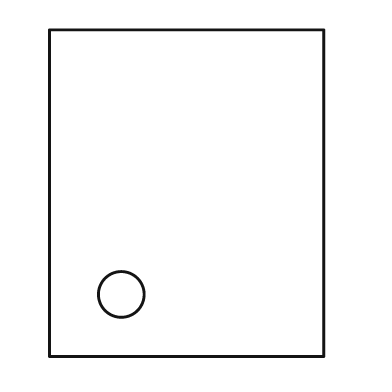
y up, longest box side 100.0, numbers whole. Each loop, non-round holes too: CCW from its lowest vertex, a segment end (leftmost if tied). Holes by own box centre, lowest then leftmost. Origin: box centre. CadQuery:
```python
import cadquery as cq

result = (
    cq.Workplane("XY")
    .moveTo(-42.0, -50.0)
    .lineTo(42.0, -50.0)
    .lineTo(42.0, 50.0)
    .lineTo(-42.0, 50.0)
    .close()
    .moveTo(-20.0, -31.0)
    .circle(7.0)
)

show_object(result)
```